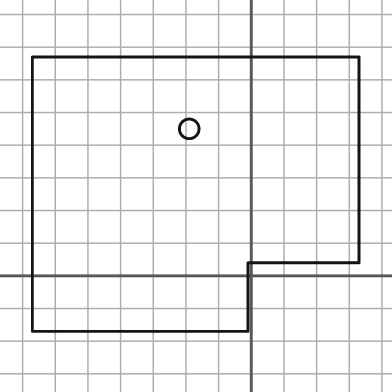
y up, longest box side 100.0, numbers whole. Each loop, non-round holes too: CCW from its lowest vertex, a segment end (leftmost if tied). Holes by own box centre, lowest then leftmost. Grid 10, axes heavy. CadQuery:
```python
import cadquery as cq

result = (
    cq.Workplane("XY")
    .moveTo(-67.0, -17.0)
    .lineTo(-1.0, -17.0)
    .lineTo(-1.0, 4.0)
    .lineTo(33.0, 4.0)
    .lineTo(33.0, 67.0)
    .lineTo(-67.0, 67.0)
    .close()
    .moveTo(-19.0, 45.0)
    .circle(3.0)
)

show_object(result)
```